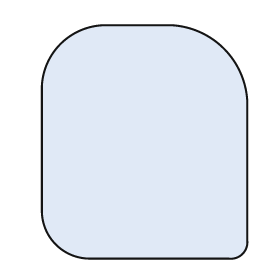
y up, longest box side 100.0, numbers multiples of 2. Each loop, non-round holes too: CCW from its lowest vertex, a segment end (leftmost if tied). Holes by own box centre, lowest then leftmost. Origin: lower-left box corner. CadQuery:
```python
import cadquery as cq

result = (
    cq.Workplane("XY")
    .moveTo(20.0, 0.0)
    .lineTo(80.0, 0.0)
    .threePointArc((86.0, 2.0), (88.0, 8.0))
    .lineTo(88.0, 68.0)
    .threePointArc((78.0, 90.0), (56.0, 100.0))
    .lineTo(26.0, 100.0)
    .threePointArc((8.0, 92.0), (0.0, 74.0))
    .lineTo(0.0, 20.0)
    .threePointArc((6.0, 6.0), (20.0, 0.0))
    .close()
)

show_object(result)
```